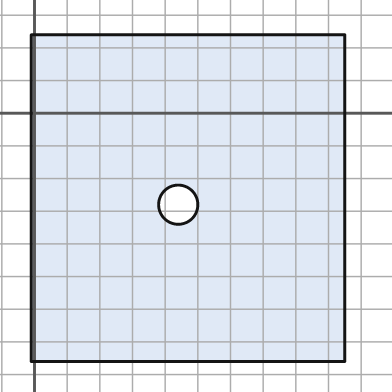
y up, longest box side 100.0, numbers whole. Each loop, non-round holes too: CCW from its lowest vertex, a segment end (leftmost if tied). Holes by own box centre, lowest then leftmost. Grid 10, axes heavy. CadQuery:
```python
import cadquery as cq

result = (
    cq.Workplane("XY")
    .moveTo(-1.0, -76.0)
    .lineTo(95.0, -76.0)
    .lineTo(95.0, 24.0)
    .lineTo(-1.0, 24.0)
    .close()
    .moveTo(44.0, -28.0)
    .circle(6.0)
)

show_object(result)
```